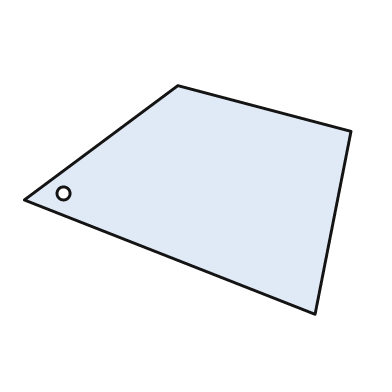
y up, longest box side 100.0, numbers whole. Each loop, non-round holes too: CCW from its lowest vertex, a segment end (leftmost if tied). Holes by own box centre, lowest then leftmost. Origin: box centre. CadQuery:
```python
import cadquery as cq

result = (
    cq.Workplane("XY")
    .moveTo(39.0, -35.0)
    .lineTo(50.0, 21.0)
    .lineTo(-3.0, 35.0)
    .lineTo(-50.0, 0.0)
    .close()
    .moveTo(-38.0, 2.0)
    .circle(2.0)
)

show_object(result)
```